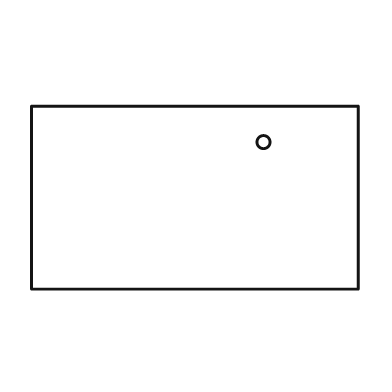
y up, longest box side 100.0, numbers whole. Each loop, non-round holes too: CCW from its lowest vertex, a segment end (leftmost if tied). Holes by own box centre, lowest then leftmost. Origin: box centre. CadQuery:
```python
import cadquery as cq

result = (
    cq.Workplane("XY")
    .moveTo(-50.0, -28.0)
    .lineTo(50.0, -28.0)
    .lineTo(50.0, 28.0)
    .lineTo(-50.0, 28.0)
    .close()
    .moveTo(21.0, 17.0)
    .circle(2.0)
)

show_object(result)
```